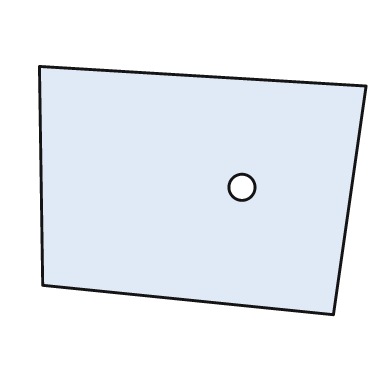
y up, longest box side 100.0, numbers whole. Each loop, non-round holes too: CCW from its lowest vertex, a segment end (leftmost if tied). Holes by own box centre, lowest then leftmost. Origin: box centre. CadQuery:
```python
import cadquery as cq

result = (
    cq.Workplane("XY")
    .moveTo(40.0, -38.0)
    .lineTo(50.0, 32.0)
    .lineTo(-50.0, 38.0)
    .lineTo(-49.0, -29.0)
    .close()
    .moveTo(12.0, 1.0)
    .circle(4.0)
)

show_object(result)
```